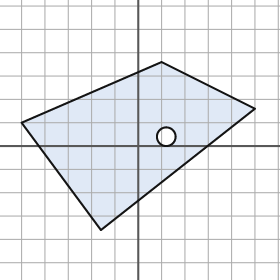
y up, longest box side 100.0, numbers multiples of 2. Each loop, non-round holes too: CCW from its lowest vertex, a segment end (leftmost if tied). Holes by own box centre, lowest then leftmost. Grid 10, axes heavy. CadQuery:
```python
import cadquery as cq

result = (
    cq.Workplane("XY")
    .moveTo(-16.0, -36.0)
    .lineTo(50.0, 16.0)
    .lineTo(10.0, 36.0)
    .lineTo(-50.0, 10.0)
    .close()
    .moveTo(12.0, 4.0)
    .circle(4.0)
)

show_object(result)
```